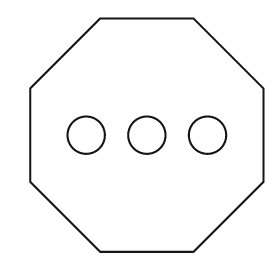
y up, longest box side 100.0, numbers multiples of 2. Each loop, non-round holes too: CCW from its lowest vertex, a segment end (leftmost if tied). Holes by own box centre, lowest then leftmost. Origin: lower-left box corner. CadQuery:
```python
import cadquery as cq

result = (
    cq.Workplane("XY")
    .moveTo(30.0, 0.0)
    .lineTo(70.0, 0.0)
    .lineTo(100.0, 30.0)
    .lineTo(100.0, 70.0)
    .lineTo(70.0, 100.0)
    .lineTo(30.0, 100.0)
    .lineTo(0.0, 70.0)
    .lineTo(0.0, 30.0)
    .close()
    .moveTo(24.0, 50.0)
    .circle(8.0)
    .moveTo(50.0, 50.0)
    .circle(8.0)
    .moveTo(76.0, 50.0)
    .circle(8.0)
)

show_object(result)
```